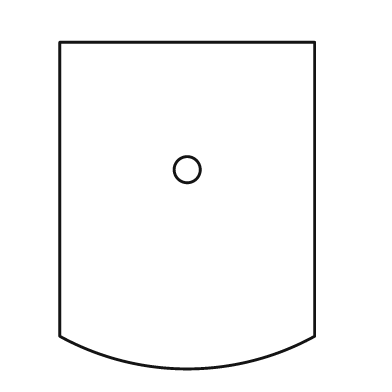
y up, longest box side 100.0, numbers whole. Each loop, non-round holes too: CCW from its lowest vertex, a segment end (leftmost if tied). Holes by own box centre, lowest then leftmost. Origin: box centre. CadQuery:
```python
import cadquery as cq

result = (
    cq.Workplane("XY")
    .moveTo(-39.0, -40.0)
    .threePointArc((0.0, -50.0), (39.0, -40.0))
    .lineTo(39.0, 50.0)
    .lineTo(-39.0, 50.0)
    .close()
    .moveTo(0.0, 11.0)
    .circle(4.0)
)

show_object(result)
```